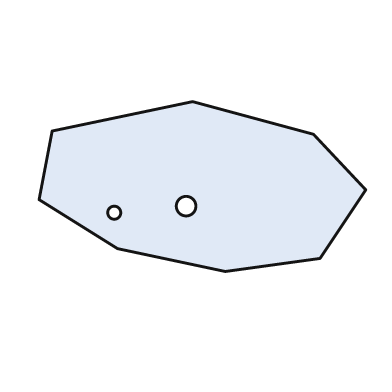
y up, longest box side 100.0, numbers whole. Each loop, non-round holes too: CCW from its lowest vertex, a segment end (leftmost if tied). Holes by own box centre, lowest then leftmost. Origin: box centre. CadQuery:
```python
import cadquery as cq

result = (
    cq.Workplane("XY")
    .moveTo(7.0, -26.0)
    .lineTo(36.0, -22.0)
    .lineTo(50.0, -1.0)
    .lineTo(34.0, 16.0)
    .lineTo(-3.0, 26.0)
    .lineTo(-46.0, 17.0)
    .lineTo(-50.0, -4.0)
    .lineTo(-26.0, -19.0)
    .close()
    .moveTo(-27.0, -8.0)
    .circle(2.0)
    .moveTo(-5.0, -6.0)
    .circle(3.0)
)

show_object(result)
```